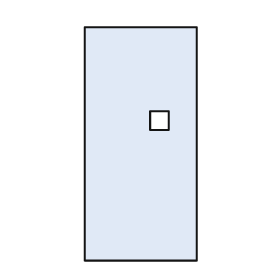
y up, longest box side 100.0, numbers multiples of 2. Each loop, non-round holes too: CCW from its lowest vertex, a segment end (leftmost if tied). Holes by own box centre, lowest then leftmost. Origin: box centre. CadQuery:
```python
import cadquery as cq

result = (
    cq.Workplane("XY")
    .moveTo(-24.0, -50.0)
    .lineTo(24.0, -50.0)
    .lineTo(24.0, 50.0)
    .lineTo(-24.0, 50.0)
    .close()
    .moveTo(4.0, 6.0)
    .lineTo(12.0, 6.0)
    .lineTo(12.0, 14.0)
    .lineTo(4.0, 14.0)
    .close()
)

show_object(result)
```